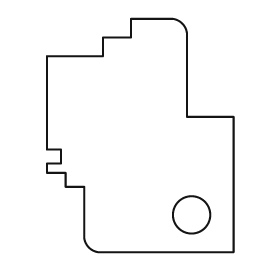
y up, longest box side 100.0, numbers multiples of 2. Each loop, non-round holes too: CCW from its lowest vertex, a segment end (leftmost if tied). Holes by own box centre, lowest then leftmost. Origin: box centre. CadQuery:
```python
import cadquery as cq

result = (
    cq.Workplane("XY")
    .moveTo(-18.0, -50.0)
    .lineTo(40.0, -50.0)
    .lineTo(40.0, 8.0)
    .lineTo(20.0, 8.0)
    .lineTo(20.0, 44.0)
    .threePointArc((18.0, 48.0), (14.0, 50.0))
    .lineTo(-4.0, 50.0)
    .lineTo(-4.0, 42.0)
    .lineTo(-16.0, 42.0)
    .lineTo(-16.0, 34.0)
    .lineTo(-40.0, 34.0)
    .lineTo(-40.0, -6.0)
    .lineTo(-34.0, -6.0)
    .lineTo(-34.0, -12.0)
    .lineTo(-40.0, -12.0)
    .lineTo(-40.0, -16.0)
    .lineTo(-32.0, -16.0)
    .lineTo(-32.0, -22.0)
    .lineTo(-24.0, -22.0)
    .lineTo(-24.0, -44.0)
    .threePointArc((-22.0, -48.0), (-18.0, -50.0))
    .close()
    .moveTo(22.0, -34.0)
    .circle(8.0)
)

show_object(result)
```